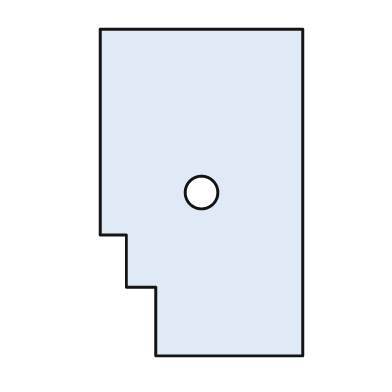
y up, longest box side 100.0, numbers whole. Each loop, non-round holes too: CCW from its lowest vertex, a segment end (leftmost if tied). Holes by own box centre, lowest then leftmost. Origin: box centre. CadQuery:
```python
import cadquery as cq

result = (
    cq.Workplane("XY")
    .moveTo(-14.0, -50.0)
    .lineTo(31.0, -50.0)
    .lineTo(31.0, 50.0)
    .lineTo(-31.0, 50.0)
    .lineTo(-31.0, -13.0)
    .lineTo(-23.0, -13.0)
    .lineTo(-23.0, -29.0)
    .lineTo(-14.0, -29.0)
    .close()
    .moveTo(0.0, 0.0)
    .circle(5.0)
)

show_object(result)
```